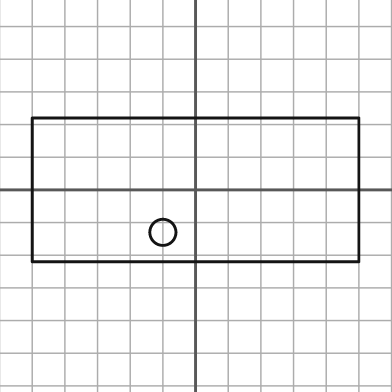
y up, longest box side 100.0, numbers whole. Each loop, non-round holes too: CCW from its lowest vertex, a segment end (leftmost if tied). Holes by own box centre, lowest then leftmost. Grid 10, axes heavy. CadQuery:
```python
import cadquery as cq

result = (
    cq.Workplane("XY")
    .moveTo(-50.0, -22.0)
    .lineTo(50.0, -22.0)
    .lineTo(50.0, 22.0)
    .lineTo(-50.0, 22.0)
    .close()
    .moveTo(-10.0, -13.0)
    .circle(4.0)
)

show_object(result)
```